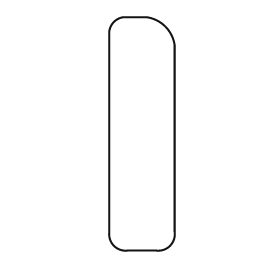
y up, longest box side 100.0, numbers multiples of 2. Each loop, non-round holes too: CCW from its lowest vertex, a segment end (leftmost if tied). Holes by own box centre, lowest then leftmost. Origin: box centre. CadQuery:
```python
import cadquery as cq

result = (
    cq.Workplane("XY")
    .moveTo(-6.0, -50.0)
    .lineTo(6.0, -50.0)
    .threePointArc((12.0, -48.0), (14.0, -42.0))
    .lineTo(14.0, 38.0)
    .threePointArc((10.0, 46.0), (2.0, 50.0))
    .lineTo(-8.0, 50.0)
    .threePointArc((-12.0, 48.0), (-14.0, 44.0))
    .lineTo(-14.0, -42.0)
    .threePointArc((-12.0, -48.0), (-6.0, -50.0))
    .close()
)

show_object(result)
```